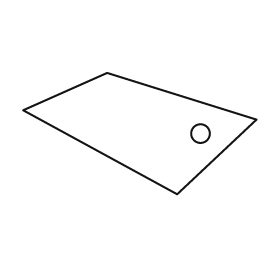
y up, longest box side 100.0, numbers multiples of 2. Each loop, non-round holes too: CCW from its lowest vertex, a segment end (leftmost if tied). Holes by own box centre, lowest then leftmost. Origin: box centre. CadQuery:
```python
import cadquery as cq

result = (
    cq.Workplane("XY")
    .moveTo(16.0, -26.0)
    .lineTo(50.0, 6.0)
    .lineTo(-14.0, 26.0)
    .lineTo(-50.0, 10.0)
    .close()
    .moveTo(26.0, 0.0)
    .circle(4.0)
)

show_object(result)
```